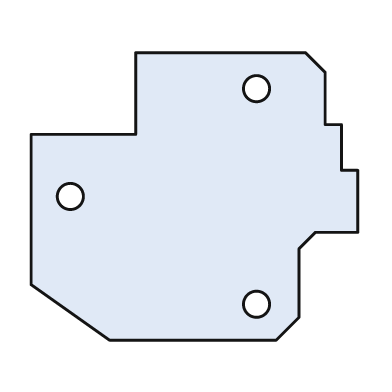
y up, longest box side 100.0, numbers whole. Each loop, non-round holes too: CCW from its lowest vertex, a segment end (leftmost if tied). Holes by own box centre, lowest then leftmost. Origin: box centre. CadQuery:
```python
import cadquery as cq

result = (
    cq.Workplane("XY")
    .moveTo(-26.0, -44.0)
    .lineTo(25.0, -44.0)
    .lineTo(32.0, -37.0)
    .lineTo(32.0, -16.0)
    .lineTo(37.0, -11.0)
    .lineTo(50.0, -11.0)
    .lineTo(50.0, 8.0)
    .lineTo(45.0, 8.0)
    .lineTo(45.0, 22.0)
    .lineTo(40.0, 22.0)
    .lineTo(40.0, 38.0)
    .lineTo(34.0, 44.0)
    .lineTo(-18.0, 44.0)
    .lineTo(-18.0, 19.0)
    .lineTo(-50.0, 19.0)
    .lineTo(-50.0, -27.0)
    .close()
    .moveTo(19.0, -33.0)
    .circle(4.0)
    .moveTo(-38.0, 0.0)
    .circle(4.0)
    .moveTo(19.0, 33.0)
    .circle(4.0)
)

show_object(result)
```